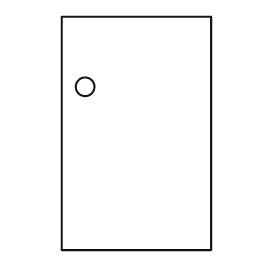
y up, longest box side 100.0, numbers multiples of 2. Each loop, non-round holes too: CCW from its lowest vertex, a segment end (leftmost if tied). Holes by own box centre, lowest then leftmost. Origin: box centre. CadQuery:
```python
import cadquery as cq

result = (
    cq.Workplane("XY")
    .moveTo(-32.0, -50.0)
    .lineTo(32.0, -50.0)
    .lineTo(32.0, 50.0)
    .lineTo(-32.0, 50.0)
    .close()
    .moveTo(-22.0, 20.0)
    .circle(4.0)
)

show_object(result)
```